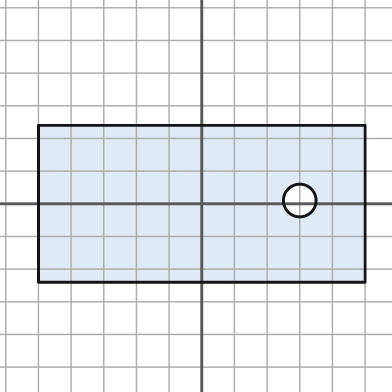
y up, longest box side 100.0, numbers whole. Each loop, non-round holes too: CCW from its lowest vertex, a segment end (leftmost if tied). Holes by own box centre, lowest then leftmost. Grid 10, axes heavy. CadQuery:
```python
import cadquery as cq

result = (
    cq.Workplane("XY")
    .moveTo(-50.0, -24.0)
    .lineTo(50.0, -24.0)
    .lineTo(50.0, 24.0)
    .lineTo(-50.0, 24.0)
    .close()
    .moveTo(30.0, 1.0)
    .circle(5.0)
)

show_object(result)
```